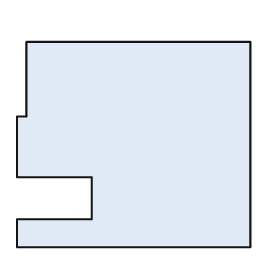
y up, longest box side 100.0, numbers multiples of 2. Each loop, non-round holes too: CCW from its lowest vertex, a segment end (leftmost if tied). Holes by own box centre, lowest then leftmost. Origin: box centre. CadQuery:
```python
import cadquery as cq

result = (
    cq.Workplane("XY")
    .moveTo(-50.0, -44.0)
    .lineTo(50.0, -44.0)
    .lineTo(50.0, 44.0)
    .lineTo(-46.0, 44.0)
    .lineTo(-46.0, 12.0)
    .lineTo(-50.0, 12.0)
    .lineTo(-50.0, -14.0)
    .lineTo(-18.0, -14.0)
    .lineTo(-18.0, -32.0)
    .lineTo(-50.0, -32.0)
    .close()
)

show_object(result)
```